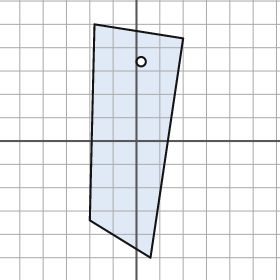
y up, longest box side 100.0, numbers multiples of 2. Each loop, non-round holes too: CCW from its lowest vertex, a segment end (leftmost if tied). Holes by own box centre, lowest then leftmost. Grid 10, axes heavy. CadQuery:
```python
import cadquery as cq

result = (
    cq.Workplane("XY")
    .moveTo(6.0, -50.0)
    .lineTo(20.0, 44.0)
    .lineTo(-18.0, 50.0)
    .lineTo(-20.0, -34.0)
    .close()
    .moveTo(2.0, 34.0)
    .circle(2.0)
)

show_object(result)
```